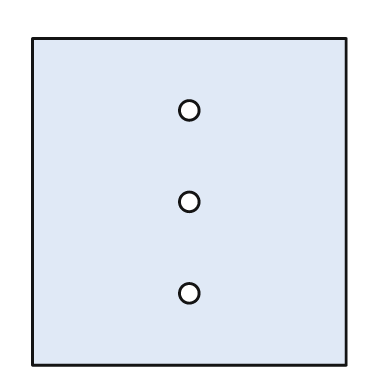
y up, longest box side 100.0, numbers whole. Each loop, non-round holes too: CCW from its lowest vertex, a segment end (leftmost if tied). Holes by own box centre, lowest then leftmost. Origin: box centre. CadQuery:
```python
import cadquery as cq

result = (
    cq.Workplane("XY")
    .moveTo(-48.0, -50.0)
    .lineTo(48.0, -50.0)
    .lineTo(48.0, 50.0)
    .lineTo(-48.0, 50.0)
    .close()
    .moveTo(0.0, -28.0)
    .circle(3.0)
    .moveTo(0.0, 0.0)
    .circle(3.0)
    .moveTo(0.0, 28.0)
    .circle(3.0)
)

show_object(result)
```